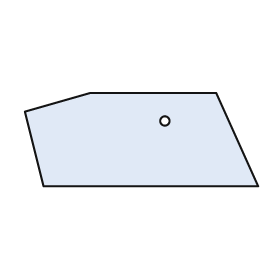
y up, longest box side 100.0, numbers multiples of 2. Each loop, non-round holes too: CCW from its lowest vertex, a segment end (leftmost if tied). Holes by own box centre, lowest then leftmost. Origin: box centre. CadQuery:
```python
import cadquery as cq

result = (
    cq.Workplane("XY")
    .moveTo(-42.0, -20.0)
    .lineTo(50.0, -20.0)
    .lineTo(32.0, 20.0)
    .lineTo(-22.0, 20.0)
    .lineTo(-50.0, 12.0)
    .close()
    .moveTo(10.0, 8.0)
    .circle(2.0)
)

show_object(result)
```